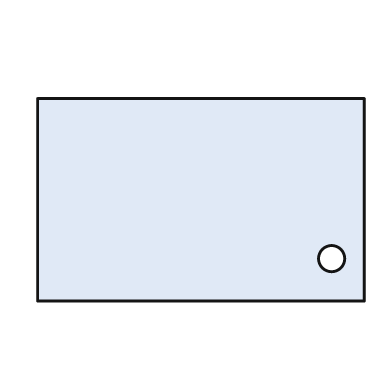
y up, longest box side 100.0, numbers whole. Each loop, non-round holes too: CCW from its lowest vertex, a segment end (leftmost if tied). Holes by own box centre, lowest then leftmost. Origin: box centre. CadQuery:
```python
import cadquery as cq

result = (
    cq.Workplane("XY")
    .moveTo(-50.0, -31.0)
    .lineTo(50.0, -31.0)
    .lineTo(50.0, 31.0)
    .lineTo(-50.0, 31.0)
    .close()
    .moveTo(40.0, -18.0)
    .circle(4.0)
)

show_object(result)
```